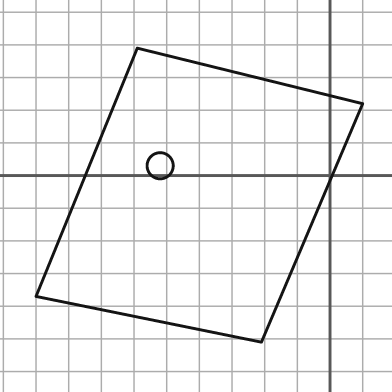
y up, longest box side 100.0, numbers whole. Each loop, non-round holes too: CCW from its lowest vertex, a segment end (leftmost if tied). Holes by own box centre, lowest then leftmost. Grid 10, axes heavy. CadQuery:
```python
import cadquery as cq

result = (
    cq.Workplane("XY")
    .moveTo(-21.0, -51.0)
    .lineTo(10.0, 22.0)
    .lineTo(-59.0, 39.0)
    .lineTo(-90.0, -37.0)
    .close()
    .moveTo(-52.0, 3.0)
    .circle(4.0)
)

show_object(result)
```